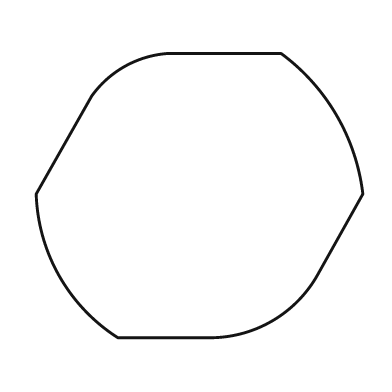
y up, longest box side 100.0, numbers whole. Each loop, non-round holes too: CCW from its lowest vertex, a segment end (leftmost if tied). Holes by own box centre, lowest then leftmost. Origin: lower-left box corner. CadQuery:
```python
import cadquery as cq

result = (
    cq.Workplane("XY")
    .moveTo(25.0, 0.0)
    .lineTo(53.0, 0.0)
    .threePointArc((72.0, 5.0), (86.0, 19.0))
    .lineTo(100.0, 44.0)
    .threePointArc((92.0, 68.0), (75.0, 87.0))
    .lineTo(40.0, 87.0)
    .threePointArc((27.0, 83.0), (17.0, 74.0))
    .lineTo(0.0, 44.0)
    .threePointArc((7.0, 19.0), (25.0, 0.0))
    .close()
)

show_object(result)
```